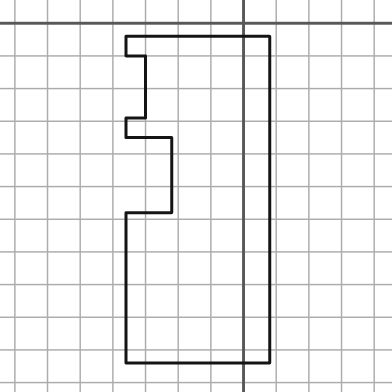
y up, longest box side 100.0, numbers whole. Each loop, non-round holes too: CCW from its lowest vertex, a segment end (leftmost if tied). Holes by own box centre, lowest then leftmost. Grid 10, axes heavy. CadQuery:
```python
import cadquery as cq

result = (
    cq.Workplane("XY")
    .moveTo(-36.0, -104.0)
    .lineTo(8.0, -104.0)
    .lineTo(8.0, -4.0)
    .lineTo(-36.0, -4.0)
    .lineTo(-36.0, -10.0)
    .lineTo(-30.0, -10.0)
    .lineTo(-30.0, -29.0)
    .lineTo(-36.0, -29.0)
    .lineTo(-36.0, -35.0)
    .lineTo(-22.0, -35.0)
    .lineTo(-22.0, -58.0)
    .lineTo(-36.0, -58.0)
    .close()
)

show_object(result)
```